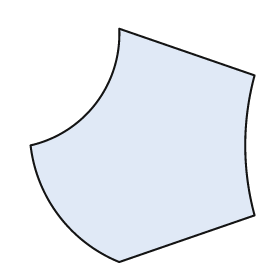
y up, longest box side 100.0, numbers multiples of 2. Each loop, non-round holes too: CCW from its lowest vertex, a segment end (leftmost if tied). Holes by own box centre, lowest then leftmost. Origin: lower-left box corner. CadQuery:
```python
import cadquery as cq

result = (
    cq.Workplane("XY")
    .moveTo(38.0, 0.0)
    .lineTo(96.0, 20.0)
    .threePointArc((92.0, 50.0), (96.0, 80.0))
    .lineTo(38.0, 100.0)
    .threePointArc((28.0, 68.0), (0.0, 50.0))
    .threePointArc((12.0, 20.0), (38.0, 0.0))
    .close()
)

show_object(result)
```